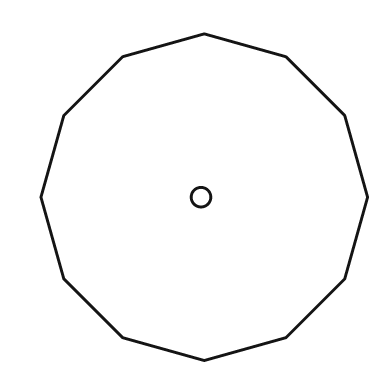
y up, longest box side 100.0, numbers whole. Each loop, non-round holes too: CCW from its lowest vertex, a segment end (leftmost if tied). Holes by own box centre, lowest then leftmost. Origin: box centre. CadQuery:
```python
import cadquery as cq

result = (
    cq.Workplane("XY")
    .moveTo(0.0, -50.0)
    .lineTo(25.0, -43.0)
    .lineTo(43.0, -25.0)
    .lineTo(50.0, 0.0)
    .lineTo(43.0, 25.0)
    .lineTo(25.0, 43.0)
    .lineTo(0.0, 50.0)
    .lineTo(-25.0, 43.0)
    .lineTo(-43.0, 25.0)
    .lineTo(-50.0, 0.0)
    .lineTo(-43.0, -25.0)
    .lineTo(-25.0, -43.0)
    .close()
    .moveTo(-1.0, 0.0)
    .circle(3.0)
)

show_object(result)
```